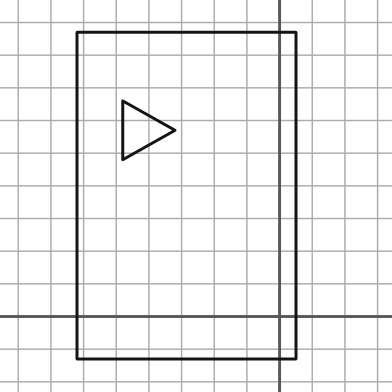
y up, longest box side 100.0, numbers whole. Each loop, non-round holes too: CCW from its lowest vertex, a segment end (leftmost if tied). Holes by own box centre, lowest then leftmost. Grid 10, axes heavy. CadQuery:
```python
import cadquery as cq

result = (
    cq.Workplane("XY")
    .moveTo(-62.0, -13.0)
    .lineTo(5.0, -13.0)
    .lineTo(5.0, 87.0)
    .lineTo(-62.0, 87.0)
    .close()
    .moveTo(-48.0, 48.0)
    .lineTo(-32.0, 57.0)
    .lineTo(-48.0, 66.0)
    .close()
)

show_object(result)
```